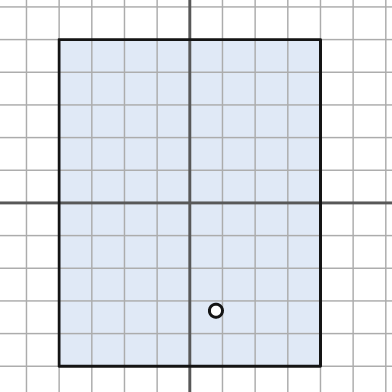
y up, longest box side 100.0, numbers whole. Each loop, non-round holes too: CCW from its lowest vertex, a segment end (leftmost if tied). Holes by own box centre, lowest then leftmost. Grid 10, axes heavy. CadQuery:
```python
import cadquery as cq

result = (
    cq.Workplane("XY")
    .moveTo(-40.0, -50.0)
    .lineTo(40.0, -50.0)
    .lineTo(40.0, 50.0)
    .lineTo(-40.0, 50.0)
    .close()
    .moveTo(8.0, -33.0)
    .circle(2.0)
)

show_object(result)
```